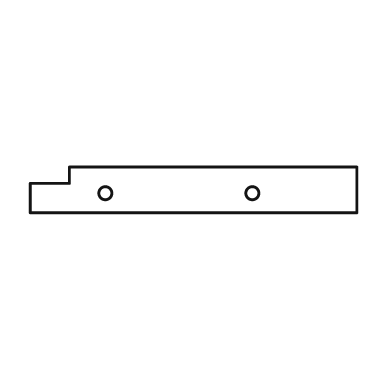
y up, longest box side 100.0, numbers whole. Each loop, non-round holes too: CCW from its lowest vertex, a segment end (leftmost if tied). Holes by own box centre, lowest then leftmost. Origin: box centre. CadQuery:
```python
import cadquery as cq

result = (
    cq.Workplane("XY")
    .moveTo(-50.0, -7.0)
    .lineTo(50.0, -7.0)
    .lineTo(50.0, 7.0)
    .lineTo(-38.0, 7.0)
    .lineTo(-38.0, 2.0)
    .lineTo(-50.0, 2.0)
    .close()
    .moveTo(-27.0, -1.0)
    .circle(2.0)
    .moveTo(18.0, -1.0)
    .circle(2.0)
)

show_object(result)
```